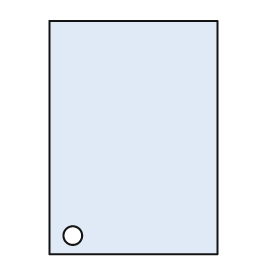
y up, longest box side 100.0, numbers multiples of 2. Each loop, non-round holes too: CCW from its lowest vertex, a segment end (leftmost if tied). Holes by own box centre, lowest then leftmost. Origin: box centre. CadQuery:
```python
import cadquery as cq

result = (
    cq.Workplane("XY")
    .moveTo(-36.0, -50.0)
    .lineTo(36.0, -50.0)
    .lineTo(36.0, 50.0)
    .lineTo(-36.0, 50.0)
    .close()
    .moveTo(-26.0, -42.0)
    .circle(4.0)
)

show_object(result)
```